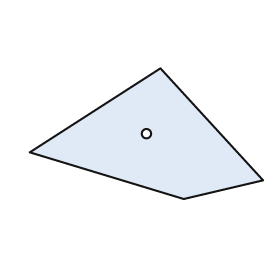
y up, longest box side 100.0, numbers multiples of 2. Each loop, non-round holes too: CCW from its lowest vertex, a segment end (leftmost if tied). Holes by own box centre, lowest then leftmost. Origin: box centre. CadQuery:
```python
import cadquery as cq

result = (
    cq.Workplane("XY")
    .moveTo(16.0, -28.0)
    .lineTo(50.0, -20.0)
    .lineTo(6.0, 28.0)
    .lineTo(-50.0, -8.0)
    .close()
    .moveTo(0.0, 0.0)
    .circle(2.0)
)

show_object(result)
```